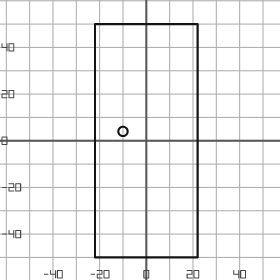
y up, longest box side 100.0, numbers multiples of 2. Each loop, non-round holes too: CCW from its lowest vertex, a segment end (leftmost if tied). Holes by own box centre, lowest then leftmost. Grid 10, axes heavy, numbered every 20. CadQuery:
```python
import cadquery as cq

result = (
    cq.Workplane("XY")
    .moveTo(-22.0, -50.0)
    .lineTo(22.0, -50.0)
    .lineTo(22.0, 50.0)
    .lineTo(-22.0, 50.0)
    .close()
    .moveTo(-10.0, 4.0)
    .circle(2.0)
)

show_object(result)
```